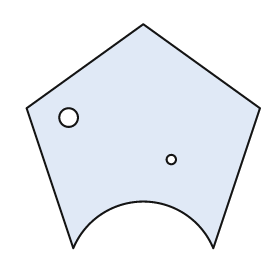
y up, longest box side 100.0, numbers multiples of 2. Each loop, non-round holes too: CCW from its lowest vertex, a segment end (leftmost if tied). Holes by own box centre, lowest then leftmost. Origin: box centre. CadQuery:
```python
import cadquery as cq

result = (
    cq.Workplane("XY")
    .moveTo(-30.0, -48.0)
    .threePointArc((0.0, -28.0), (30.0, -48.0))
    .lineTo(50.0, 12.0)
    .lineTo(0.0, 48.0)
    .lineTo(-50.0, 12.0)
    .close()
    .moveTo(12.0, -10.0)
    .circle(2.0)
    .moveTo(-32.0, 8.0)
    .circle(4.0)
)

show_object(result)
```